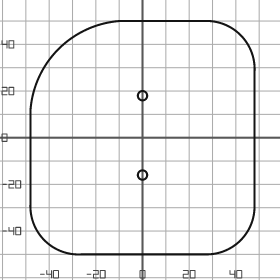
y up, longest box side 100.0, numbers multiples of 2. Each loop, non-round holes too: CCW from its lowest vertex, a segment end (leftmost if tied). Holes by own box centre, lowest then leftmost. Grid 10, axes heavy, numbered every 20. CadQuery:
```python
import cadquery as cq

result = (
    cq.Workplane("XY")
    .moveTo(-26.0, -50.0)
    .lineTo(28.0, -50.0)
    .threePointArc((42.0, -44.0), (48.0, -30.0))
    .lineTo(48.0, 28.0)
    .threePointArc((42.0, 44.0), (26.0, 50.0))
    .lineTo(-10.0, 50.0)
    .threePointArc((-36.0, 38.0), (-48.0, 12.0))
    .lineTo(-48.0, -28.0)
    .threePointArc((-42.0, -44.0), (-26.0, -50.0))
    .close()
    .moveTo(0.0, -16.0)
    .circle(2.0)
    .moveTo(0.0, 18.0)
    .circle(2.0)
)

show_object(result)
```